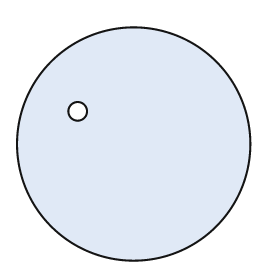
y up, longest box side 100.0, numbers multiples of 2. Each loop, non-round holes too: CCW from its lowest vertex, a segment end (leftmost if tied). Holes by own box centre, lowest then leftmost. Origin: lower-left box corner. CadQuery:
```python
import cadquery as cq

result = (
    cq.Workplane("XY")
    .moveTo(50.0, 50.0)
    .circle(50.0)
    .moveTo(26.0, 64.0)
    .circle(4.0)
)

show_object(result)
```